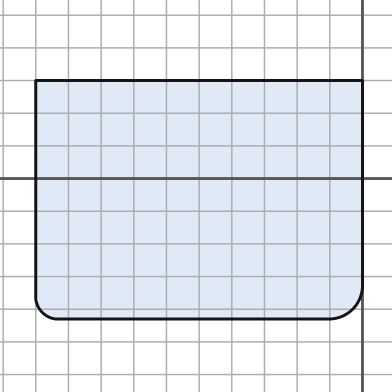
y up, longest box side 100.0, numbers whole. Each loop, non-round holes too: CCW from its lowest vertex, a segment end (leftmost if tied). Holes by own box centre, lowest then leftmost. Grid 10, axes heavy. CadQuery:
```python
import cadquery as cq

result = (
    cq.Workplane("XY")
    .moveTo(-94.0, -43.0)
    .lineTo(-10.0, -43.0)
    .threePointArc((-3.0, -40.0), (0.0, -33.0))
    .lineTo(0.0, 30.0)
    .lineTo(-100.0, 30.0)
    .lineTo(-100.0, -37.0)
    .threePointArc((-98.0, -41.0), (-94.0, -43.0))
    .close()
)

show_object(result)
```